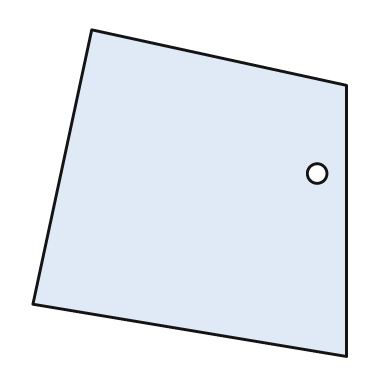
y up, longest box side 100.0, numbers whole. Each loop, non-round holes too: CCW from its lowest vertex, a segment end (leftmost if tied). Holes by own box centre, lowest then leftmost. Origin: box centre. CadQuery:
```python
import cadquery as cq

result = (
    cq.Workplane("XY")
    .moveTo(48.0, -50.0)
    .lineTo(48.0, 33.0)
    .lineTo(-30.0, 50.0)
    .lineTo(-48.0, -34.0)
    .close()
    .moveTo(39.0, 6.0)
    .circle(3.0)
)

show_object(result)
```